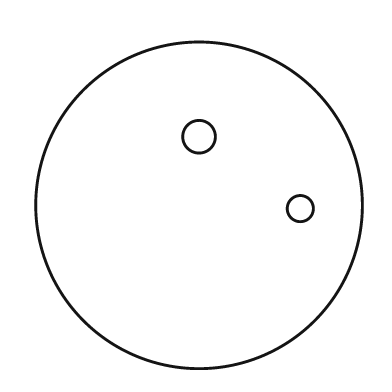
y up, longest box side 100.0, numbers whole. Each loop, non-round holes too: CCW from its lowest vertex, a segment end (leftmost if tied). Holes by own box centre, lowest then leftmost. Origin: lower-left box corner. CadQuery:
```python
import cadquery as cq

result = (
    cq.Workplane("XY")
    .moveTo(50.0, 50.0)
    .circle(50.0)
    .moveTo(81.0, 49.0)
    .circle(4.0)
    .moveTo(50.0, 71.0)
    .circle(5.0)
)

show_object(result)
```